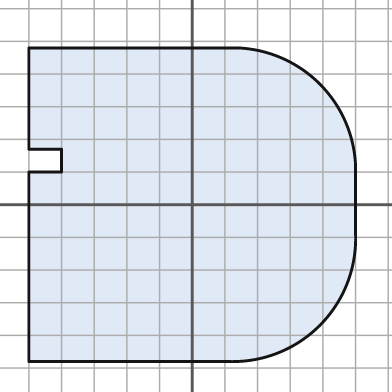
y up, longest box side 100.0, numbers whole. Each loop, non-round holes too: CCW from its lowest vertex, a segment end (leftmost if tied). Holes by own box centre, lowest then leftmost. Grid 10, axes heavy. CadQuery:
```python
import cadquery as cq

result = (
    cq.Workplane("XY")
    .moveTo(-50.0, -48.0)
    .lineTo(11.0, -48.0)
    .threePointArc((39.0, -37.0), (50.0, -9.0))
    .lineTo(50.0, 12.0)
    .threePointArc((39.0, 37.0), (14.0, 48.0))
    .lineTo(-50.0, 48.0)
    .lineTo(-50.0, 17.0)
    .lineTo(-40.0, 17.0)
    .lineTo(-40.0, 10.0)
    .lineTo(-50.0, 10.0)
    .close()
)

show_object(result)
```